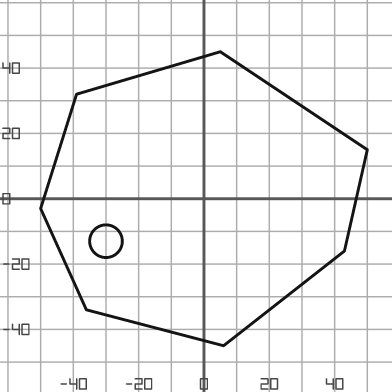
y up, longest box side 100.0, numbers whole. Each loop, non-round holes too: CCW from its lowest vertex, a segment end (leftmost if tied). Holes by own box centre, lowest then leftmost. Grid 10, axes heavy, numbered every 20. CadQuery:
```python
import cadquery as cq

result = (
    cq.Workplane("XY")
    .moveTo(6.0, -45.0)
    .lineTo(43.0, -16.0)
    .lineTo(50.0, 15.0)
    .lineTo(5.0, 45.0)
    .lineTo(-39.0, 32.0)
    .lineTo(-50.0, -3.0)
    .lineTo(-36.0, -34.0)
    .close()
    .moveTo(-30.0, -13.0)
    .circle(5.0)
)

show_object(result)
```